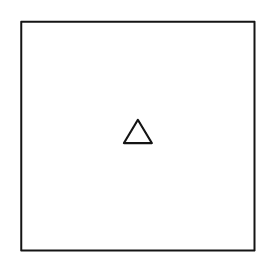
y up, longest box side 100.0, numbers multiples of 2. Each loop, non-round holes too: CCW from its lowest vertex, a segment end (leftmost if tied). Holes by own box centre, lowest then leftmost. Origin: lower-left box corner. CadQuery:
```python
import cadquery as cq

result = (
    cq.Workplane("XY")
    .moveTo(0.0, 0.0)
    .lineTo(100.0, 0.0)
    .lineTo(100.0, 98.0)
    .lineTo(0.0, 98.0)
    .close()
    .moveTo(44.0, 46.0)
    .lineTo(56.0, 46.0)
    .lineTo(50.0, 56.0)
    .close()
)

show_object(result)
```